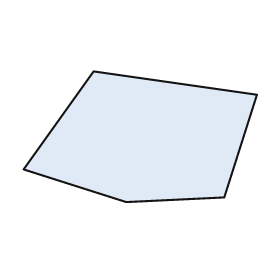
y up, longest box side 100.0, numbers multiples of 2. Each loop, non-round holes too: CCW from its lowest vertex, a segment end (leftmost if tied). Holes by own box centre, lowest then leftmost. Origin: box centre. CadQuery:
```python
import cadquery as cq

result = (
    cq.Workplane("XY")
    .moveTo(-6.0, -28.0)
    .lineTo(36.0, -26.0)
    .lineTo(50.0, 18.0)
    .lineTo(-20.0, 28.0)
    .lineTo(-50.0, -14.0)
    .close()
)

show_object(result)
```